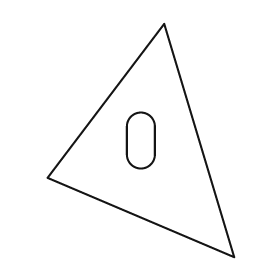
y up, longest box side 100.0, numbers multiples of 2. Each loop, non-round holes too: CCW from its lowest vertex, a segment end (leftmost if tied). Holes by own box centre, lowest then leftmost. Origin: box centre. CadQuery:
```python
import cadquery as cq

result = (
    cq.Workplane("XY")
    .moveTo(40.0, -50.0)
    .lineTo(10.0, 50.0)
    .lineTo(-40.0, -16.0)
    .close()
    .moveTo(-6.0, -6.0)
    .threePointArc((0.0, -12.0), (6.0, -6.0))
    .lineTo(6.0, 6.0)
    .threePointArc((0.0, 12.0), (-6.0, 6.0))
    .close()
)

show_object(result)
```